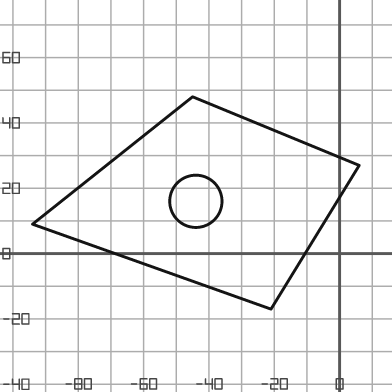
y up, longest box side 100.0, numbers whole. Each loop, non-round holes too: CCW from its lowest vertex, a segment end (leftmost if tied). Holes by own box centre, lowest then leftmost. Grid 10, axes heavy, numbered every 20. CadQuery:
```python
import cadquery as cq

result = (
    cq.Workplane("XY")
    .moveTo(-21.0, -17.0)
    .lineTo(6.0, 27.0)
    .lineTo(-45.0, 48.0)
    .lineTo(-94.0, 9.0)
    .close()
    .moveTo(-44.0, 16.0)
    .circle(8.0)
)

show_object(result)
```